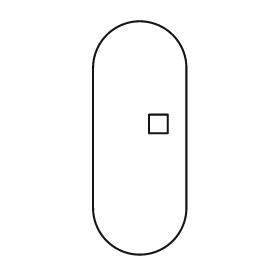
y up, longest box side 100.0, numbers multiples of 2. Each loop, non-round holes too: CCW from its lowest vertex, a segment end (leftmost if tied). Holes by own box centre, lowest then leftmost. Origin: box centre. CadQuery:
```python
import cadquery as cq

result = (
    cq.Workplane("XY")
    .moveTo(-20.0, -30.0)
    .threePointArc((0.0, -50.0), (20.0, -30.0))
    .lineTo(20.0, 30.0)
    .threePointArc((0.0, 50.0), (-20.0, 30.0))
    .close()
    .moveTo(4.0, 2.0)
    .lineTo(12.0, 2.0)
    .lineTo(12.0, 10.0)
    .lineTo(4.0, 10.0)
    .close()
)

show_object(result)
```